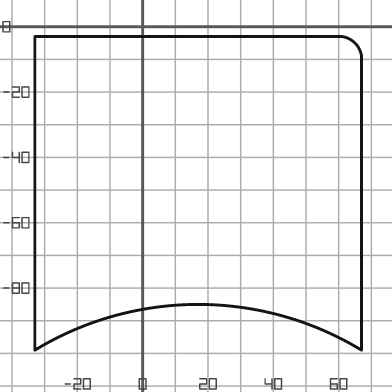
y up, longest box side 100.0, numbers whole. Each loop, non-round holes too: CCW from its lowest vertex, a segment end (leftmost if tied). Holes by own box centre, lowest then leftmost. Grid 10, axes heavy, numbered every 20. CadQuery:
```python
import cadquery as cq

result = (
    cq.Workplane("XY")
    .moveTo(-33.0, -99.0)
    .threePointArc((17.0, -85.0), (67.0, -99.0))
    .lineTo(67.0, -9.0)
    .threePointArc((65.0, -5.0), (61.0, -3.0))
    .lineTo(-33.0, -3.0)
    .close()
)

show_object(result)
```